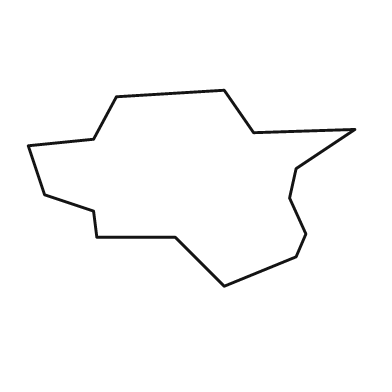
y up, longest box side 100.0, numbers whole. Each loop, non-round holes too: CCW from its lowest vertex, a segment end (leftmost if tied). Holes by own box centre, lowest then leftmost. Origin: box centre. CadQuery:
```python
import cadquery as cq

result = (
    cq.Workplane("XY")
    .moveTo(10.0, -30.0)
    .lineTo(32.0, -21.0)
    .lineTo(35.0, -14.0)
    .lineTo(30.0, -3.0)
    .lineTo(32.0, 6.0)
    .lineTo(50.0, 18.0)
    .lineTo(19.0, 17.0)
    .lineTo(10.0, 30.0)
    .lineTo(-23.0, 28.0)
    .lineTo(-30.0, 15.0)
    .lineTo(-50.0, 13.0)
    .lineTo(-45.0, -2.0)
    .lineTo(-30.0, -7.0)
    .lineTo(-29.0, -15.0)
    .lineTo(-5.0, -15.0)
    .close()
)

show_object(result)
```